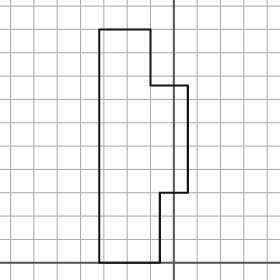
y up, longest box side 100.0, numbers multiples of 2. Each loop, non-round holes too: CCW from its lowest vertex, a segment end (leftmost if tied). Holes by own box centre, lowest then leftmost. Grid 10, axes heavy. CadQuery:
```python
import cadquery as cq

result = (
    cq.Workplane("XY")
    .moveTo(-32.0, 0.0)
    .lineTo(-6.0, 0.0)
    .lineTo(-6.0, 30.0)
    .lineTo(6.0, 30.0)
    .lineTo(6.0, 76.0)
    .lineTo(-10.0, 76.0)
    .lineTo(-10.0, 100.0)
    .lineTo(-32.0, 100.0)
    .close()
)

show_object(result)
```